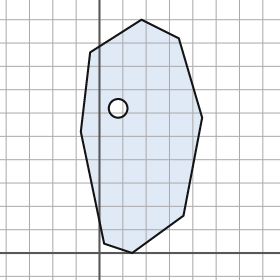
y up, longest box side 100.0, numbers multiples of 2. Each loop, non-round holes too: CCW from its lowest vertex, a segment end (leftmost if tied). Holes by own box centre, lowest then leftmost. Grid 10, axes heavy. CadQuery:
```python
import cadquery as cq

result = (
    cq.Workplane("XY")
    .moveTo(14.0, 0.0)
    .lineTo(36.0, 16.0)
    .lineTo(44.0, 58.0)
    .lineTo(34.0, 92.0)
    .lineTo(18.0, 100.0)
    .lineTo(-4.0, 86.0)
    .lineTo(-8.0, 52.0)
    .lineTo(2.0, 4.0)
    .close()
    .moveTo(8.0, 62.0)
    .circle(4.0)
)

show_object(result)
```